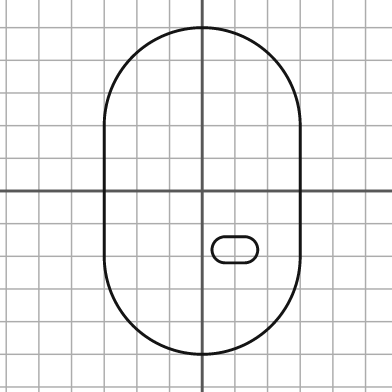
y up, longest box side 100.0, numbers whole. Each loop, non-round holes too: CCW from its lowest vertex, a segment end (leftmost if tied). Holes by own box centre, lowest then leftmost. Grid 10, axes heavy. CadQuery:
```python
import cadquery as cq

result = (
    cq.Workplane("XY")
    .moveTo(-30.0, -20.0)
    .threePointArc((0.0, -50.0), (30.0, -20.0))
    .lineTo(30.0, 20.0)
    .threePointArc((0.0, 50.0), (-30.0, 20.0))
    .close()
    .moveTo(7.0, -22.0)
    .lineTo(13.0, -22.0)
    .threePointArc((17.0, -18.0), (13.0, -14.0))
    .lineTo(7.0, -14.0)
    .threePointArc((3.0, -18.0), (7.0, -22.0))
    .close()
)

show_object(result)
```